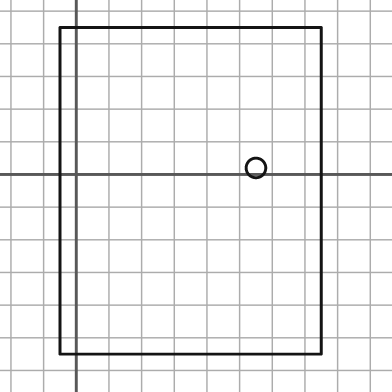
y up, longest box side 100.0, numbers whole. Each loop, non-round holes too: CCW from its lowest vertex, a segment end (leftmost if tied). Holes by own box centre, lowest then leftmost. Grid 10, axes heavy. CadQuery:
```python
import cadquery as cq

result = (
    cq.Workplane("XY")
    .moveTo(-5.0, -55.0)
    .lineTo(75.0, -55.0)
    .lineTo(75.0, 45.0)
    .lineTo(-5.0, 45.0)
    .close()
    .moveTo(55.0, 2.0)
    .circle(3.0)
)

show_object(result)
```